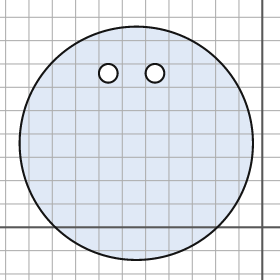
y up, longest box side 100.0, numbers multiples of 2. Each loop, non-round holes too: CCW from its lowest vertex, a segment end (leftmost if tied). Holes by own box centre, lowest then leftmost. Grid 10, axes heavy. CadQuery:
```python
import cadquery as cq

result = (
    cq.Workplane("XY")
    .moveTo(-54.0, 36.0)
    .circle(50.0)
    .moveTo(-66.0, 66.0)
    .circle(4.0)
    .moveTo(-46.0, 66.0)
    .circle(4.0)
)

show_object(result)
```